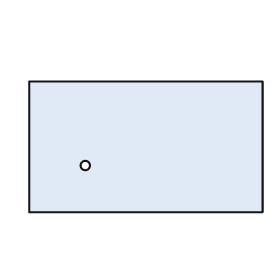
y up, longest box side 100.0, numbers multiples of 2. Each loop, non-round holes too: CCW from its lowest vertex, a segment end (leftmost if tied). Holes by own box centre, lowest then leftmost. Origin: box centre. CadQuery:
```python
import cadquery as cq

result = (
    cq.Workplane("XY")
    .moveTo(-50.0, -28.0)
    .lineTo(50.0, -28.0)
    .lineTo(50.0, 28.0)
    .lineTo(-50.0, 28.0)
    .close()
    .moveTo(-26.0, -8.0)
    .circle(2.0)
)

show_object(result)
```